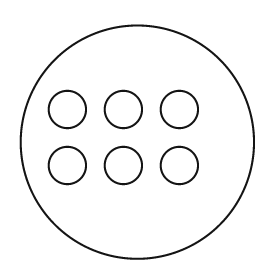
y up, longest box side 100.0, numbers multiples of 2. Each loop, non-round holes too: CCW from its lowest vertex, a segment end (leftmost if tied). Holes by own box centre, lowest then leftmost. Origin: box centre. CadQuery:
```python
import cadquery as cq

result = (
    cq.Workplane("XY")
    .moveTo(0.0, 0.0)
    .circle(50.0)
    .moveTo(-30.0, -10.0)
    .circle(8.0)
    .moveTo(-6.0, -10.0)
    .circle(8.0)
    .moveTo(18.0, -10.0)
    .circle(8.0)
    .moveTo(-30.0, 14.0)
    .circle(8.0)
    .moveTo(-6.0, 14.0)
    .circle(8.0)
    .moveTo(18.0, 14.0)
    .circle(8.0)
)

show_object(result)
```